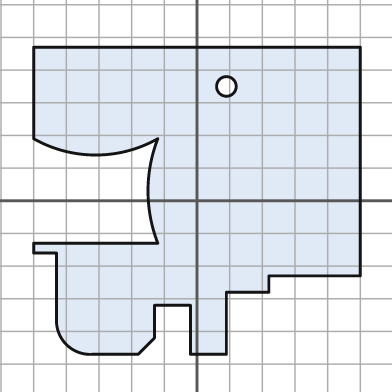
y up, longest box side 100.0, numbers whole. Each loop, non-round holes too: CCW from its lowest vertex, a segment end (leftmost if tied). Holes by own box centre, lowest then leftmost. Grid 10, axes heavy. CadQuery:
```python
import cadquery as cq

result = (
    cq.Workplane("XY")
    .moveTo(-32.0, -47.0)
    .lineTo(-18.0, -47.0)
    .lineTo(-13.0, -42.0)
    .lineTo(-13.0, -32.0)
    .lineTo(-2.0, -32.0)
    .lineTo(-2.0, -47.0)
    .lineTo(9.0, -47.0)
    .lineTo(9.0, -28.0)
    .lineTo(22.0, -28.0)
    .lineTo(22.0, -23.0)
    .lineTo(50.0, -23.0)
    .lineTo(50.0, 47.0)
    .lineTo(-50.0, 47.0)
    .lineTo(-50.0, 19.0)
    .threePointArc((-31.0, 14.0), (-12.0, 19.0))
    .threePointArc((-15.0, 3.0), (-12.0, -13.0))
    .lineTo(-50.0, -13.0)
    .lineTo(-50.0, -16.0)
    .lineTo(-43.0, -16.0)
    .lineTo(-43.0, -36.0)
    .threePointArc((-40.0, -44.0), (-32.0, -47.0))
    .close()
    .moveTo(9.0, 35.0)
    .circle(3.0)
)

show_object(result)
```